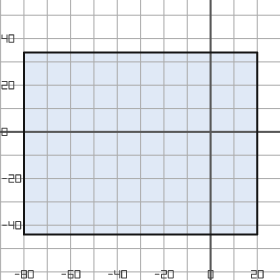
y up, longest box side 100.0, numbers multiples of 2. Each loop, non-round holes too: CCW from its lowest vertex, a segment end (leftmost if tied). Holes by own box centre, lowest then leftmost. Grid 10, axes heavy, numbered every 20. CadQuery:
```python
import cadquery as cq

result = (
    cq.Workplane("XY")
    .moveTo(-80.0, -44.0)
    .lineTo(20.0, -44.0)
    .lineTo(20.0, 34.0)
    .lineTo(-80.0, 34.0)
    .close()
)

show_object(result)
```